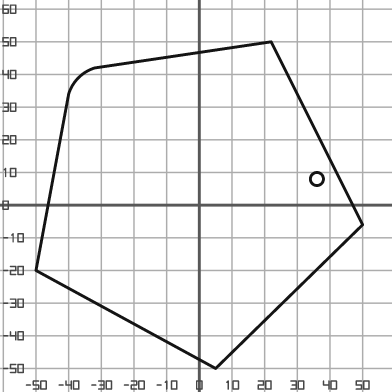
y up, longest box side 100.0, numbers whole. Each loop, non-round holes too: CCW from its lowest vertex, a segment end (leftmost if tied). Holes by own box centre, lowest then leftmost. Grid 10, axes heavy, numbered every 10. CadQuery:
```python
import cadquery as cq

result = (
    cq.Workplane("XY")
    .moveTo(5.0, -50.0)
    .lineTo(50.0, -6.0)
    .lineTo(22.0, 50.0)
    .lineTo(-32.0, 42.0)
    .threePointArc((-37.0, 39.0), (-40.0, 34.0))
    .lineTo(-50.0, -20.0)
    .close()
    .moveTo(36.0, 8.0)
    .circle(2.0)
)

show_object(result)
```